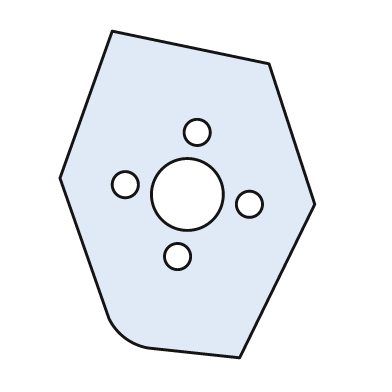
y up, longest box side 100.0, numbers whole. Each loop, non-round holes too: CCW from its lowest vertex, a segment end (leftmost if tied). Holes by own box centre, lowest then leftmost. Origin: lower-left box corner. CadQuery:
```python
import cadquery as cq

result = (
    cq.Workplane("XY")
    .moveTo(55.0, 0.0)
    .lineTo(78.0, 47.0)
    .lineTo(64.0, 90.0)
    .lineTo(16.0, 100.0)
    .lineTo(0.0, 55.0)
    .lineTo(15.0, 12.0)
    .threePointArc((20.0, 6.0), (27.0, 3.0))
    .close()
    .moveTo(36.0, 31.0)
    .circle(4.0)
    .moveTo(58.0, 47.0)
    .circle(4.0)
    .moveTo(39.0, 50.0)
    .circle(11.0)
    .moveTo(20.0, 53.0)
    .circle(4.0)
    .moveTo(42.0, 69.0)
    .circle(4.0)
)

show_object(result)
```